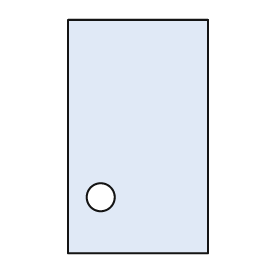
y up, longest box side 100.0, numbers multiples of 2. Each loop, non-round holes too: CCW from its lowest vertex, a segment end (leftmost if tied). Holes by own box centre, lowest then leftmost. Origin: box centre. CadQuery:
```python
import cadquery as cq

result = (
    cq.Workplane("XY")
    .moveTo(-30.0, -50.0)
    .lineTo(30.0, -50.0)
    .lineTo(30.0, 50.0)
    .lineTo(-30.0, 50.0)
    .close()
    .moveTo(-16.0, -26.0)
    .circle(6.0)
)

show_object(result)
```